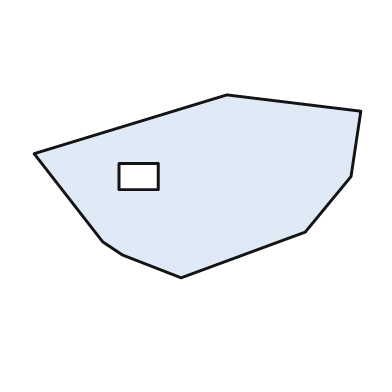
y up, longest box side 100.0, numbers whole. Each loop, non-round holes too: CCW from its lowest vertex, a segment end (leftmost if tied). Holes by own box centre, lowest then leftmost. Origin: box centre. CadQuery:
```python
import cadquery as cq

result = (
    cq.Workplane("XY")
    .moveTo(-5.0, -28.0)
    .lineTo(33.0, -14.0)
    .lineTo(47.0, 3.0)
    .lineTo(50.0, 23.0)
    .lineTo(9.0, 28.0)
    .lineTo(-50.0, 10.0)
    .lineTo(-29.0, -17.0)
    .lineTo(-23.0, -21.0)
    .close()
    .moveTo(-24.0, -1.0)
    .lineTo(-12.0, -1.0)
    .lineTo(-12.0, 7.0)
    .lineTo(-24.0, 7.0)
    .close()
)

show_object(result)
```